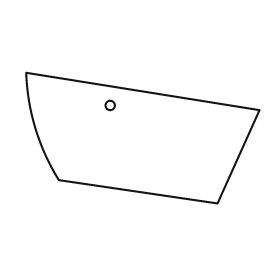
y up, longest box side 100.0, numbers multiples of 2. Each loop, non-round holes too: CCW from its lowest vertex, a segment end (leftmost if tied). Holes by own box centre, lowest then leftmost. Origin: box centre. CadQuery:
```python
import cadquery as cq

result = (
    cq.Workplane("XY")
    .moveTo(32.0, -28.0)
    .lineTo(50.0, 12.0)
    .lineTo(-50.0, 28.0)
    .threePointArc((-46.0, 4.0), (-36.0, -18.0))
    .close()
    .moveTo(-14.0, 14.0)
    .circle(2.0)
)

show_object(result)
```